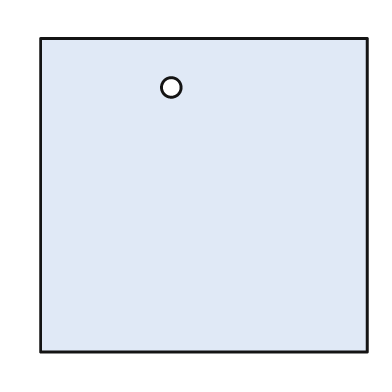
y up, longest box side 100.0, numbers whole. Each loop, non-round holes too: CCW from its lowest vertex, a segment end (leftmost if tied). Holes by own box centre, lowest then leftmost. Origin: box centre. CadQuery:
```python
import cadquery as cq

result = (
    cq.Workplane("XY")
    .moveTo(-50.0, -48.0)
    .lineTo(50.0, -48.0)
    .lineTo(50.0, 48.0)
    .lineTo(-50.0, 48.0)
    .close()
    .moveTo(-10.0, 33.0)
    .circle(3.0)
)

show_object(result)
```